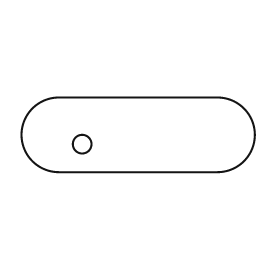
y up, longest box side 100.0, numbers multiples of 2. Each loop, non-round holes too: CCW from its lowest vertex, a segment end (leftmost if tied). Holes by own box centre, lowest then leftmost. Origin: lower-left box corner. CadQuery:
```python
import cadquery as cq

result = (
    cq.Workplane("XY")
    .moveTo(16.0, 0.0)
    .lineTo(84.0, 0.0)
    .threePointArc((100.0, 16.0), (84.0, 32.0))
    .lineTo(16.0, 32.0)
    .threePointArc((0.0, 16.0), (16.0, 0.0))
    .close()
    .moveTo(26.0, 12.0)
    .circle(4.0)
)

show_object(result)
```